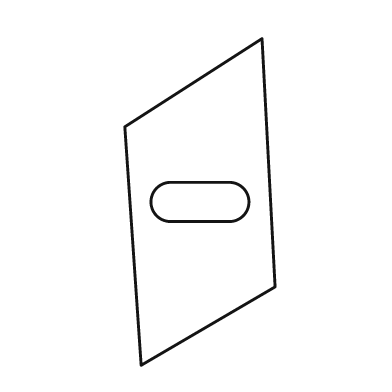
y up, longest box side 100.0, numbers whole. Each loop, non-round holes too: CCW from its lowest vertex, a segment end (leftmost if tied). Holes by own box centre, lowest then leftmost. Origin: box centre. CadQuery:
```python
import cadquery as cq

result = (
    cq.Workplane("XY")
    .moveTo(-18.0, -50.0)
    .lineTo(23.0, -26.0)
    .lineTo(19.0, 50.0)
    .lineTo(-23.0, 23.0)
    .close()
    .moveTo(-9.0, -6.0)
    .lineTo(9.0, -6.0)
    .threePointArc((15.0, 0.0), (9.0, 6.0))
    .lineTo(-9.0, 6.0)
    .threePointArc((-15.0, 0.0), (-9.0, -6.0))
    .close()
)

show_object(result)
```